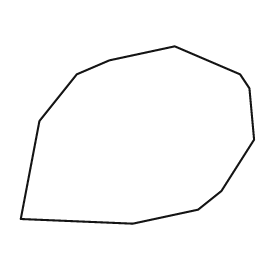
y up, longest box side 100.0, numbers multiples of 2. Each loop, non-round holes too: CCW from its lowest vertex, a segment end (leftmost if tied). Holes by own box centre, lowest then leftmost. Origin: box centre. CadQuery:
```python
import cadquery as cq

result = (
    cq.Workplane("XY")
    .moveTo(-2.0, -38.0)
    .lineTo(26.0, -32.0)
    .lineTo(36.0, -24.0)
    .lineTo(50.0, -2.0)
    .lineTo(48.0, 20.0)
    .lineTo(44.0, 26.0)
    .lineTo(16.0, 38.0)
    .lineTo(-12.0, 32.0)
    .lineTo(-26.0, 26.0)
    .lineTo(-42.0, 6.0)
    .lineTo(-50.0, -36.0)
    .close()
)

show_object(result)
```